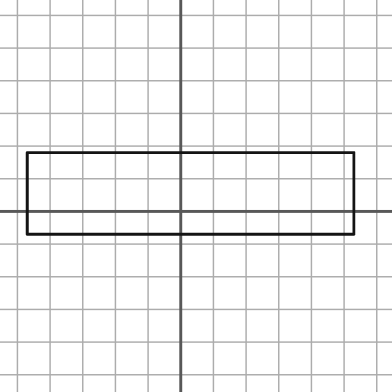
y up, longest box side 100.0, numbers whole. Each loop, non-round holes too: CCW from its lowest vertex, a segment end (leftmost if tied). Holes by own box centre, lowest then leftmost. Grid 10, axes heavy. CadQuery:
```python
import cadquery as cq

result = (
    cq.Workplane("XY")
    .moveTo(-47.0, -7.0)
    .lineTo(53.0, -7.0)
    .lineTo(53.0, 18.0)
    .lineTo(-47.0, 18.0)
    .close()
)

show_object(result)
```